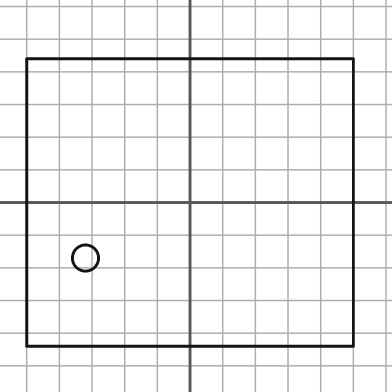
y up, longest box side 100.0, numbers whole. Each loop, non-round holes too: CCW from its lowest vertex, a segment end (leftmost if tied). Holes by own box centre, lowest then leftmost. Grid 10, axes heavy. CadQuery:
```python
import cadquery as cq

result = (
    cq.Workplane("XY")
    .moveTo(-50.0, -44.0)
    .lineTo(50.0, -44.0)
    .lineTo(50.0, 44.0)
    .lineTo(-50.0, 44.0)
    .close()
    .moveTo(-32.0, -17.0)
    .circle(4.0)
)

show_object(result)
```